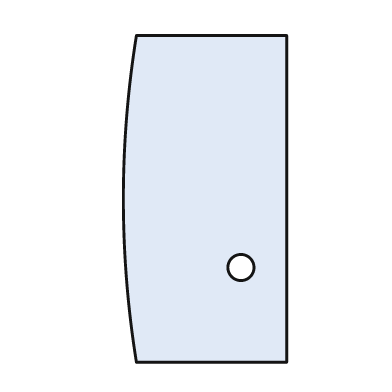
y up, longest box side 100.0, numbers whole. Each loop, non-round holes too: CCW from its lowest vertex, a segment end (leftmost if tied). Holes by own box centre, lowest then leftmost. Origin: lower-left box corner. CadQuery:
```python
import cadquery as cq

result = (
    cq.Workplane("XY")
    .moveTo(4.0, 0.0)
    .lineTo(50.0, 0.0)
    .lineTo(50.0, 100.0)
    .lineTo(4.0, 100.0)
    .threePointArc((0.0, 50.0), (4.0, 0.0))
    .close()
    .moveTo(36.0, 29.0)
    .circle(4.0)
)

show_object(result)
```